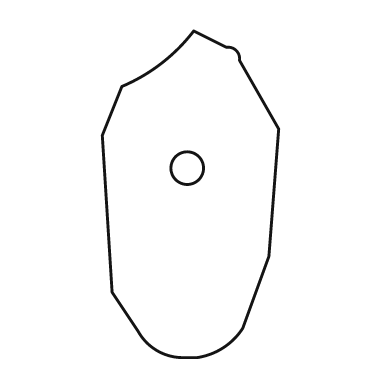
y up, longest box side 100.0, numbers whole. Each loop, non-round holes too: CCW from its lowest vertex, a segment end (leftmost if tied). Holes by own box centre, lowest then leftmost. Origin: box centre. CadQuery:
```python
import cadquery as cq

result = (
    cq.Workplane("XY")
    .moveTo(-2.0, -50.0)
    .lineTo(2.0, -50.0)
    .threePointArc((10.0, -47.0), (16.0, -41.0))
    .lineTo(24.0, -19.0)
    .lineTo(27.0, 20.0)
    .lineTo(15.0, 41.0)
    .threePointArc((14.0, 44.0), (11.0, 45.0))
    .lineTo(1.0, 50.0)
    .threePointArc((-9.0, 40.0), (-21.0, 33.0))
    .lineTo(-27.0, 18.0)
    .lineTo(-24.0, -30.0)
    .lineTo(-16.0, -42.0)
    .threePointArc((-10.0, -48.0), (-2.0, -50.0))
    .close()
    .moveTo(-1.0, 8.0)
    .circle(5.0)
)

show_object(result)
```